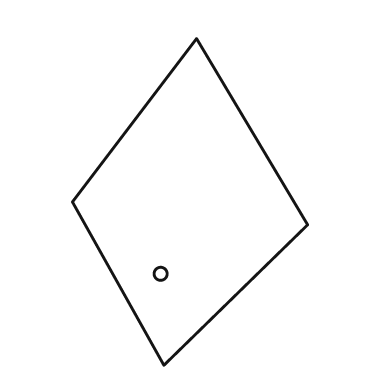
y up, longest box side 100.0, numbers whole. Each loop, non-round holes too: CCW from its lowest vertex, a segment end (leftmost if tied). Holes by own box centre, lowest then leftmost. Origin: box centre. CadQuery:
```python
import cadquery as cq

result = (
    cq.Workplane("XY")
    .moveTo(-8.0, -50.0)
    .lineTo(36.0, -7.0)
    .lineTo(2.0, 50.0)
    .lineTo(-36.0, 0.0)
    .close()
    .moveTo(-9.0, -22.0)
    .circle(2.0)
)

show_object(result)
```